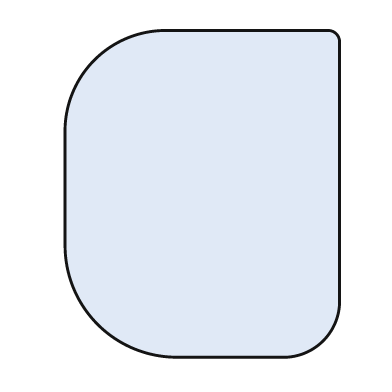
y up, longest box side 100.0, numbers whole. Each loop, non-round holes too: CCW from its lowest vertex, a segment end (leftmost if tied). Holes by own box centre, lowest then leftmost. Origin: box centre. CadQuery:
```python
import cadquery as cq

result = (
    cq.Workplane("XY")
    .moveTo(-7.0, -50.0)
    .lineTo(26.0, -50.0)
    .threePointArc((37.0, -45.0), (42.0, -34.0))
    .lineTo(42.0, 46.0)
    .threePointArc((41.0, 49.0), (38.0, 50.0))
    .lineTo(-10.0, 50.0)
    .threePointArc((-33.0, 41.0), (-42.0, 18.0))
    .lineTo(-42.0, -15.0)
    .threePointArc((-32.0, -40.0), (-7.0, -50.0))
    .close()
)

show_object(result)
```